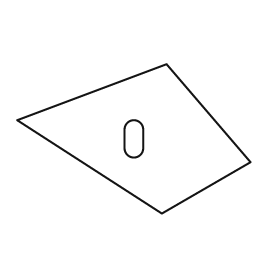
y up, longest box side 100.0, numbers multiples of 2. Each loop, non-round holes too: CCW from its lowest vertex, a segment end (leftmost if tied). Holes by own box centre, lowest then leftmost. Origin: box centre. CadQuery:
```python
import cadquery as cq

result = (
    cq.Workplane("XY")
    .moveTo(12.0, -32.0)
    .lineTo(50.0, -10.0)
    .lineTo(14.0, 32.0)
    .lineTo(-50.0, 8.0)
    .close()
    .moveTo(-4.0, -4.0)
    .threePointArc((0.0, -8.0), (4.0, -4.0))
    .lineTo(4.0, 4.0)
    .threePointArc((0.0, 8.0), (-4.0, 4.0))
    .close()
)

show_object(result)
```